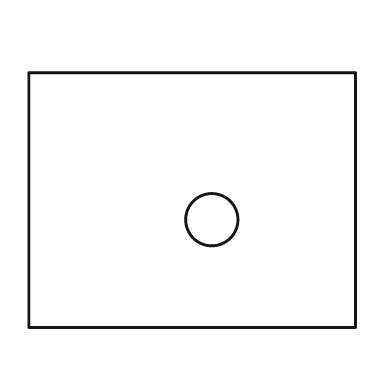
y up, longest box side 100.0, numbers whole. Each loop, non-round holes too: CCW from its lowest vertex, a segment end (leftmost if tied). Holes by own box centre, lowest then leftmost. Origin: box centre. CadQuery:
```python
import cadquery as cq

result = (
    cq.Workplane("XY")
    .moveTo(-50.0, -39.0)
    .lineTo(50.0, -39.0)
    .lineTo(50.0, 39.0)
    .lineTo(-50.0, 39.0)
    .close()
    .moveTo(6.0, -6.0)
    .circle(8.0)
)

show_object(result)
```